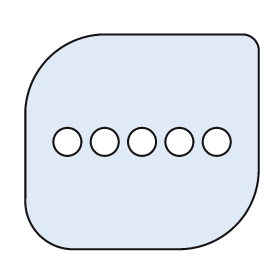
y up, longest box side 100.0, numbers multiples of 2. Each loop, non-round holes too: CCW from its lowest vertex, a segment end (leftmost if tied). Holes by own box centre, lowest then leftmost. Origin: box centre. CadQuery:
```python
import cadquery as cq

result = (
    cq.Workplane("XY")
    .moveTo(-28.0, -46.0)
    .lineTo(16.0, -46.0)
    .threePointArc((40.0, -36.0), (50.0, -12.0))
    .lineTo(50.0, 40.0)
    .threePointArc((48.0, 44.0), (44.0, 46.0))
    .lineTo(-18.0, 46.0)
    .threePointArc((-40.0, 36.0), (-50.0, 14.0))
    .lineTo(-50.0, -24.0)
    .threePointArc((-44.0, -40.0), (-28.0, -46.0))
    .close()
    .moveTo(-32.0, 0.0)
    .circle(6.0)
    .moveTo(-16.0, 0.0)
    .circle(6.0)
    .moveTo(0.0, 0.0)
    .circle(6.0)
    .moveTo(16.0, 0.0)
    .circle(6.0)
    .moveTo(32.0, 0.0)
    .circle(6.0)
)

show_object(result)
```